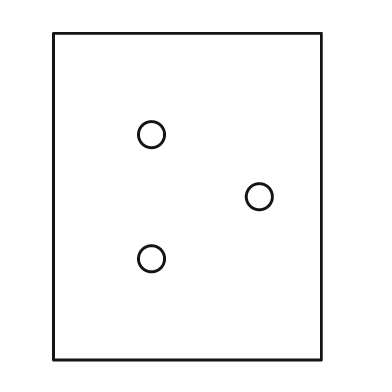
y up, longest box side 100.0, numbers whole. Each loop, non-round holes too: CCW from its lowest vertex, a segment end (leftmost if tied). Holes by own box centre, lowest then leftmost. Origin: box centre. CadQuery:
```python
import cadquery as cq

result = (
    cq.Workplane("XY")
    .moveTo(-41.0, -50.0)
    .lineTo(41.0, -50.0)
    .lineTo(41.0, 50.0)
    .lineTo(-41.0, 50.0)
    .close()
    .moveTo(-11.0, -19.0)
    .circle(4.0)
    .moveTo(22.0, 0.0)
    .circle(4.0)
    .moveTo(-11.0, 19.0)
    .circle(4.0)
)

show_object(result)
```